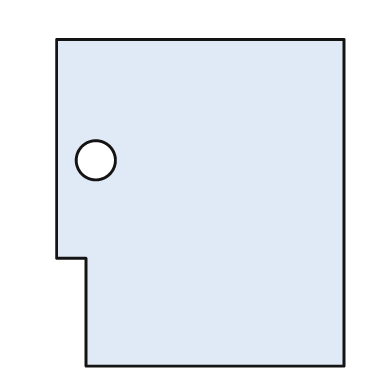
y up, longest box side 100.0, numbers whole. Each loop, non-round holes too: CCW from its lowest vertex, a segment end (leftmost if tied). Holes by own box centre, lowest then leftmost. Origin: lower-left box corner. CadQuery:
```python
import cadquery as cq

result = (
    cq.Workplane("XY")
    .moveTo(9.0, 0.0)
    .lineTo(88.0, 0.0)
    .lineTo(88.0, 100.0)
    .lineTo(0.0, 100.0)
    .lineTo(0.0, 33.0)
    .lineTo(9.0, 33.0)
    .close()
    .moveTo(12.0, 63.0)
    .circle(6.0)
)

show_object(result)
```